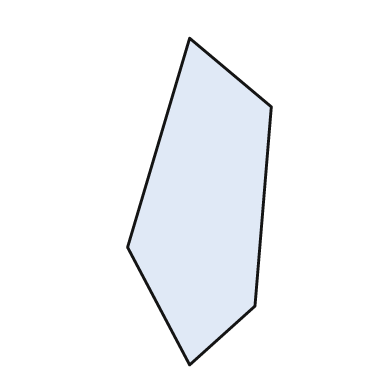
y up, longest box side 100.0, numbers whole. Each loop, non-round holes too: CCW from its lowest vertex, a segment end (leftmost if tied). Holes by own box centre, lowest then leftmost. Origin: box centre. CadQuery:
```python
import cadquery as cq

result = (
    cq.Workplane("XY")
    .moveTo(-3.0, -50.0)
    .lineTo(17.0, -32.0)
    .lineTo(22.0, 29.0)
    .lineTo(-3.0, 50.0)
    .lineTo(-22.0, -14.0)
    .close()
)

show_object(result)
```